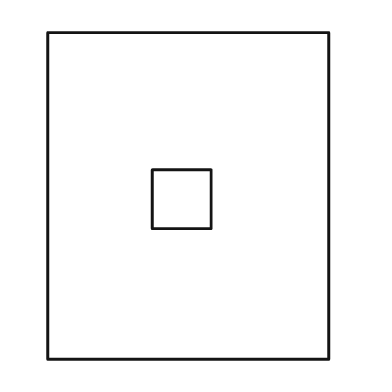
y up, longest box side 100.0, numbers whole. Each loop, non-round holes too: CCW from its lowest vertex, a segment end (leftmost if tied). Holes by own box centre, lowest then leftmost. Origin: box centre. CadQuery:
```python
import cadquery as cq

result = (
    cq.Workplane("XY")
    .moveTo(-43.0, -50.0)
    .lineTo(43.0, -50.0)
    .lineTo(43.0, 50.0)
    .lineTo(-43.0, 50.0)
    .close()
    .moveTo(-11.0, -10.0)
    .lineTo(7.0, -10.0)
    .lineTo(7.0, 8.0)
    .lineTo(-11.0, 8.0)
    .close()
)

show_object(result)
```